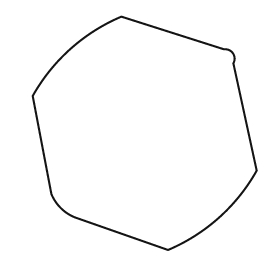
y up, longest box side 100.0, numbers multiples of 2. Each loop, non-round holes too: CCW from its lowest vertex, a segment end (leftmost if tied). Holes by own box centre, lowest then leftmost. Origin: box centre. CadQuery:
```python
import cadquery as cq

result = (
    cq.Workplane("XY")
    .moveTo(10.0, -50.0)
    .threePointArc((32.0, -36.0), (48.0, -16.0))
    .lineTo(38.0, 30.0)
    .threePointArc((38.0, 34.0), (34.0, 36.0))
    .lineTo(-10.0, 50.0)
    .threePointArc((-32.0, 36.0), (-48.0, 16.0))
    .lineTo(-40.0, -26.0)
    .threePointArc((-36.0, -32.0), (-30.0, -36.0))
    .close()
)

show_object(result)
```